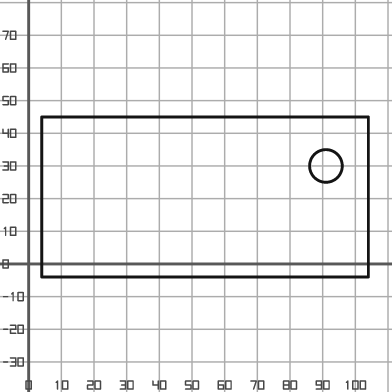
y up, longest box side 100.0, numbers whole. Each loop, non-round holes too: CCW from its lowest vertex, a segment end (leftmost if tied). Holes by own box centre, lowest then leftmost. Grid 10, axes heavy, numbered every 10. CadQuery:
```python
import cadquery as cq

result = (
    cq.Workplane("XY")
    .moveTo(4.0, -4.0)
    .lineTo(104.0, -4.0)
    .lineTo(104.0, 45.0)
    .lineTo(4.0, 45.0)
    .close()
    .moveTo(91.0, 30.0)
    .circle(5.0)
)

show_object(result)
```